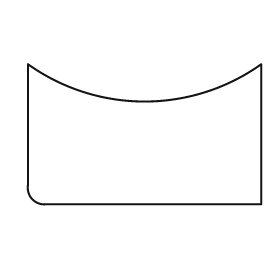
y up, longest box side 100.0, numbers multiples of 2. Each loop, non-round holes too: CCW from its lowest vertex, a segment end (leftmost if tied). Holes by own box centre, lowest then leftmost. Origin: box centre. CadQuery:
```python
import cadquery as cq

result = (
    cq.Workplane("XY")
    .moveTo(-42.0, -30.0)
    .lineTo(50.0, -30.0)
    .lineTo(50.0, 30.0)
    .threePointArc((0.0, 14.0), (-50.0, 30.0))
    .lineTo(-50.0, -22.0)
    .threePointArc((-48.0, -28.0), (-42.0, -30.0))
    .close()
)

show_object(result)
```